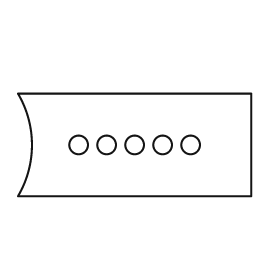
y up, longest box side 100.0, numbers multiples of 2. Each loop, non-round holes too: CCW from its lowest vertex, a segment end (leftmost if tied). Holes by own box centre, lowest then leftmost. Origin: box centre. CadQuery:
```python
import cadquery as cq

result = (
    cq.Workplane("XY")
    .moveTo(-50.0, -22.0)
    .lineTo(50.0, -22.0)
    .lineTo(50.0, 22.0)
    .lineTo(-50.0, 22.0)
    .threePointArc((-44.0, 0.0), (-50.0, -22.0))
    .close()
    .moveTo(-24.0, 0.0)
    .circle(4.0)
    .moveTo(-12.0, 0.0)
    .circle(4.0)
    .moveTo(0.0, 0.0)
    .circle(4.0)
    .moveTo(12.0, 0.0)
    .circle(4.0)
    .moveTo(24.0, 0.0)
    .circle(4.0)
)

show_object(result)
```